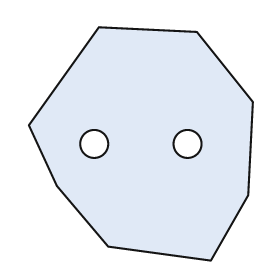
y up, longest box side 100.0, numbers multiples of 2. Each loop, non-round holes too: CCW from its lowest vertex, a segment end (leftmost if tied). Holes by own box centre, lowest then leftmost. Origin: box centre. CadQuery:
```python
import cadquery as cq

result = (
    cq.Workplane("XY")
    .moveTo(30.0, -50.0)
    .lineTo(46.0, -22.0)
    .lineTo(48.0, 18.0)
    .lineTo(24.0, 48.0)
    .lineTo(-18.0, 50.0)
    .lineTo(-48.0, 8.0)
    .lineTo(-36.0, -18.0)
    .lineTo(-14.0, -44.0)
    .close()
    .moveTo(-20.0, 0.0)
    .circle(6.0)
    .moveTo(20.0, 0.0)
    .circle(6.0)
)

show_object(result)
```